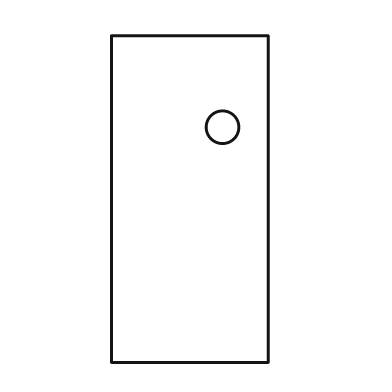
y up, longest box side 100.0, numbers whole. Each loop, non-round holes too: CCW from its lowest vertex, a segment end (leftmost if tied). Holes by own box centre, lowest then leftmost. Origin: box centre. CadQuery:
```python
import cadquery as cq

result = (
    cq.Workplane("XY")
    .moveTo(-24.0, -50.0)
    .lineTo(24.0, -50.0)
    .lineTo(24.0, 50.0)
    .lineTo(-24.0, 50.0)
    .close()
    .moveTo(10.0, 22.0)
    .circle(5.0)
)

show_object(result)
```